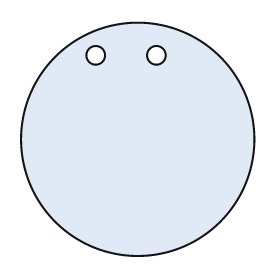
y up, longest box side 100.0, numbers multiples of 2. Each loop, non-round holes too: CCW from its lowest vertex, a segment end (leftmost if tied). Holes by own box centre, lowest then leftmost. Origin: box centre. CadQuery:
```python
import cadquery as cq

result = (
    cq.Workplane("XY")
    .moveTo(0.0, 0.0)
    .circle(50.0)
    .moveTo(-18.0, 36.0)
    .circle(4.0)
    .moveTo(8.0, 36.0)
    .circle(4.0)
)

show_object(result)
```